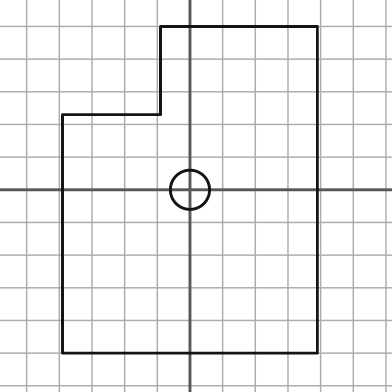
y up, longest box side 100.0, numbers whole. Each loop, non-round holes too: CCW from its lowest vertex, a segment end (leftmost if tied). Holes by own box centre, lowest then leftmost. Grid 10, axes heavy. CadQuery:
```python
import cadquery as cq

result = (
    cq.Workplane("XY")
    .moveTo(-39.0, -50.0)
    .lineTo(39.0, -50.0)
    .lineTo(39.0, 50.0)
    .lineTo(-9.0, 50.0)
    .lineTo(-9.0, 23.0)
    .lineTo(-39.0, 23.0)
    .close()
    .moveTo(0.0, 0.0)
    .circle(6.0)
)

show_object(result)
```